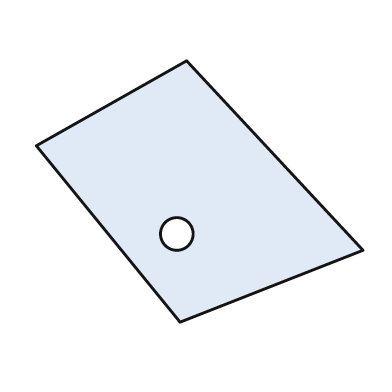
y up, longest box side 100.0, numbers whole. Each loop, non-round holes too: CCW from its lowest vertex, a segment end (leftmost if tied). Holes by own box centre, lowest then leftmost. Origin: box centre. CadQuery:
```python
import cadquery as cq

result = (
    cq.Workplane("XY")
    .moveTo(-6.0, -40.0)
    .lineTo(50.0, -18.0)
    .lineTo(-4.0, 40.0)
    .lineTo(-50.0, 14.0)
    .close()
    .moveTo(-7.0, -13.0)
    .circle(5.0)
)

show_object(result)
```